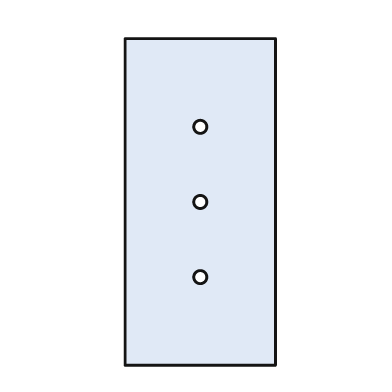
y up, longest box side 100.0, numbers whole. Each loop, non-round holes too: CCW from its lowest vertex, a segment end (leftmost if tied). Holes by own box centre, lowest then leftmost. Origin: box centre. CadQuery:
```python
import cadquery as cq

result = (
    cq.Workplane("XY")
    .moveTo(-23.0, -50.0)
    .lineTo(23.0, -50.0)
    .lineTo(23.0, 50.0)
    .lineTo(-23.0, 50.0)
    .close()
    .moveTo(0.0, -23.0)
    .circle(2.0)
    .moveTo(0.0, 0.0)
    .circle(2.0)
    .moveTo(0.0, 23.0)
    .circle(2.0)
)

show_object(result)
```